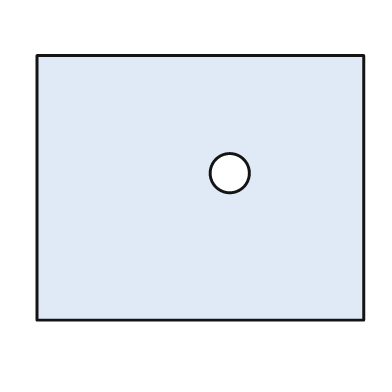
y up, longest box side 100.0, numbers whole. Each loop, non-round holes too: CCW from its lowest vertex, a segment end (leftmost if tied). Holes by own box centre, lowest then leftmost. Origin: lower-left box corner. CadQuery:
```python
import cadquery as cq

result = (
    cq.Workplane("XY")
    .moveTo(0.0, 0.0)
    .lineTo(100.0, 0.0)
    .lineTo(100.0, 81.0)
    .lineTo(0.0, 81.0)
    .close()
    .moveTo(59.0, 45.0)
    .circle(6.0)
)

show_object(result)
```